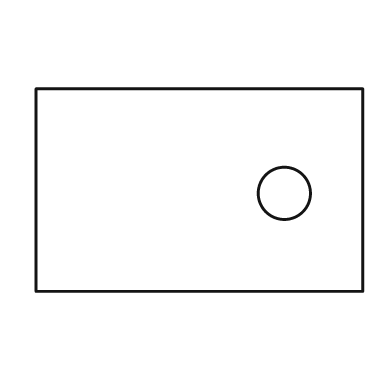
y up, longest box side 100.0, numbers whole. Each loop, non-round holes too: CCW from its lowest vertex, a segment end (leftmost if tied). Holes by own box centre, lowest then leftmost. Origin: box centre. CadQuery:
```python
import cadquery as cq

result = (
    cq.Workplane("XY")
    .moveTo(-50.0, -31.0)
    .lineTo(50.0, -31.0)
    .lineTo(50.0, 31.0)
    .lineTo(-50.0, 31.0)
    .close()
    .moveTo(26.0, -1.0)
    .circle(8.0)
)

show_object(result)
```